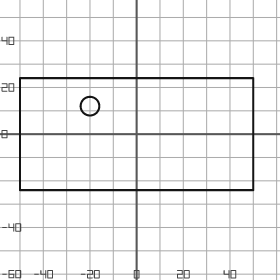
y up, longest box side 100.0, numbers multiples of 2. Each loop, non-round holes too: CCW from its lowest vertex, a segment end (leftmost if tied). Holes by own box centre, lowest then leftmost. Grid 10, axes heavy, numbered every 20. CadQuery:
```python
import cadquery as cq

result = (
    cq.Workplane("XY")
    .moveTo(-50.0, -24.0)
    .lineTo(50.0, -24.0)
    .lineTo(50.0, 24.0)
    .lineTo(-50.0, 24.0)
    .close()
    .moveTo(-20.0, 12.0)
    .circle(4.0)
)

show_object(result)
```